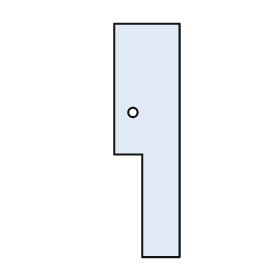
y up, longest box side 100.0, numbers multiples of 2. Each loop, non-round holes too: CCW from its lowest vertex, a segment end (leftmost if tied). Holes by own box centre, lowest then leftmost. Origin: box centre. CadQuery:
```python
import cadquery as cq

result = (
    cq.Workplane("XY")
    .moveTo(-2.0, -50.0)
    .lineTo(14.0, -50.0)
    .lineTo(14.0, 50.0)
    .lineTo(-14.0, 50.0)
    .lineTo(-14.0, -6.0)
    .lineTo(-2.0, -6.0)
    .close()
    .moveTo(-6.0, 12.0)
    .circle(2.0)
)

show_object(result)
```